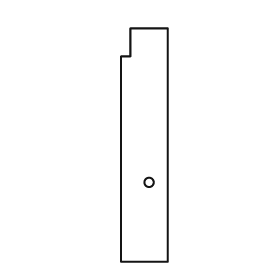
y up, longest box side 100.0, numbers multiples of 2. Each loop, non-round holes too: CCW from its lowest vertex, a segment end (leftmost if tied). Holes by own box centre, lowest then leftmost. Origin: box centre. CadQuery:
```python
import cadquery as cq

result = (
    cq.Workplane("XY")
    .moveTo(-10.0, -50.0)
    .lineTo(10.0, -50.0)
    .lineTo(10.0, 50.0)
    .lineTo(-6.0, 50.0)
    .lineTo(-6.0, 38.0)
    .lineTo(-10.0, 38.0)
    .close()
    .moveTo(2.0, -16.0)
    .circle(2.0)
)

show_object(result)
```